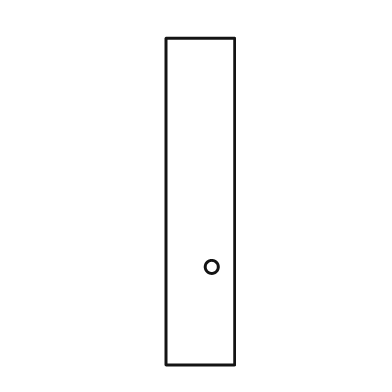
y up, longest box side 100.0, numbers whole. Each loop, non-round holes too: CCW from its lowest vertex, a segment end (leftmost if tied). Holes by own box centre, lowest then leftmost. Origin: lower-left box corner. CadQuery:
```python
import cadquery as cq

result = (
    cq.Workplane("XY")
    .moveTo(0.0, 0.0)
    .lineTo(21.0, 0.0)
    .lineTo(21.0, 100.0)
    .lineTo(0.0, 100.0)
    .close()
    .moveTo(14.0, 30.0)
    .circle(2.0)
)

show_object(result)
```